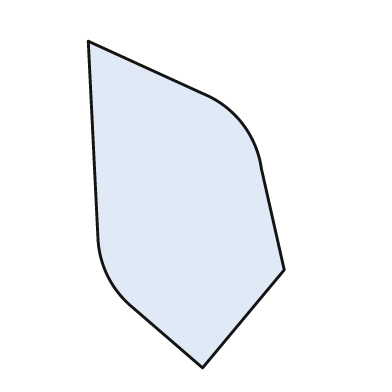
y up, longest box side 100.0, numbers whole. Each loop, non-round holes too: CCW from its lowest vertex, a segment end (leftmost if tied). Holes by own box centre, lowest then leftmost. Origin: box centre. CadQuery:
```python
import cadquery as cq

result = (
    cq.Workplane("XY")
    .moveTo(5.0, -50.0)
    .lineTo(30.0, -20.0)
    .lineTo(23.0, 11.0)
    .threePointArc((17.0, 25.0), (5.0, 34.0))
    .lineTo(-30.0, 50.0)
    .lineTo(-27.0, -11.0)
    .threePointArc((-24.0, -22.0), (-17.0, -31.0))
    .close()
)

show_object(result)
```